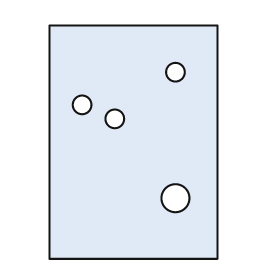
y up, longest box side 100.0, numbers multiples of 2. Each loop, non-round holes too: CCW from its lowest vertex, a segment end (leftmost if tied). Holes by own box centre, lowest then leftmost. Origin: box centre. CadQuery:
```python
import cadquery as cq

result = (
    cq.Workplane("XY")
    .moveTo(-36.0, -50.0)
    .lineTo(36.0, -50.0)
    .lineTo(36.0, 50.0)
    .lineTo(-36.0, 50.0)
    .close()
    .moveTo(18.0, -24.0)
    .circle(6.0)
    .moveTo(-8.0, 10.0)
    .circle(4.0)
    .moveTo(-22.0, 16.0)
    .circle(4.0)
    .moveTo(18.0, 30.0)
    .circle(4.0)
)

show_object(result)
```